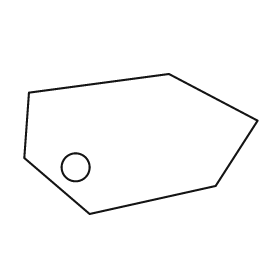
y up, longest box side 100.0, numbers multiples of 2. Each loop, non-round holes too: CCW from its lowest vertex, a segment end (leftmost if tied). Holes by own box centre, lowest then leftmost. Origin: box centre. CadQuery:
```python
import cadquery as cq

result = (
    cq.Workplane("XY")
    .moveTo(-22.0, -30.0)
    .lineTo(32.0, -18.0)
    .lineTo(50.0, 10.0)
    .lineTo(12.0, 30.0)
    .lineTo(-48.0, 22.0)
    .lineTo(-50.0, -6.0)
    .close()
    .moveTo(-28.0, -10.0)
    .circle(6.0)
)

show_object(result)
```